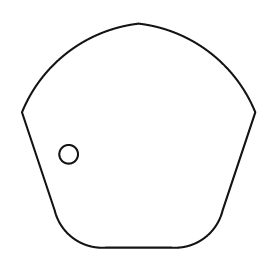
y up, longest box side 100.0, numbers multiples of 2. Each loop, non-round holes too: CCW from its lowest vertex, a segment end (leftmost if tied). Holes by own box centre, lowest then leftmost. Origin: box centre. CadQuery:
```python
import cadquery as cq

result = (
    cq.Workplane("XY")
    .moveTo(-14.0, -48.0)
    .lineTo(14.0, -48.0)
    .threePointArc((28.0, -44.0), (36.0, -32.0))
    .lineTo(50.0, 10.0)
    .threePointArc((30.0, 36.0), (0.0, 48.0))
    .threePointArc((-30.0, 36.0), (-50.0, 10.0))
    .lineTo(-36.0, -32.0)
    .threePointArc((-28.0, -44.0), (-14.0, -48.0))
    .close()
    .moveTo(-30.0, -8.0)
    .circle(4.0)
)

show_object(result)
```